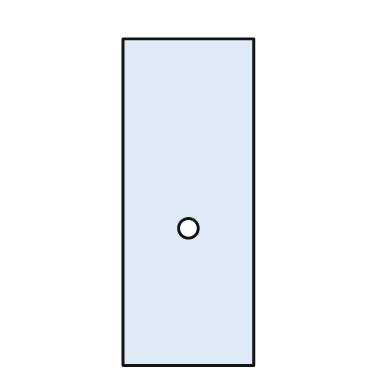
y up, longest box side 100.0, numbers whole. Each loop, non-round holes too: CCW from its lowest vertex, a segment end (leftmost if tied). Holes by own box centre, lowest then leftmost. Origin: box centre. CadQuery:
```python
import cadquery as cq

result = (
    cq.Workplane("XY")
    .moveTo(-20.0, -50.0)
    .lineTo(20.0, -50.0)
    .lineTo(20.0, 50.0)
    .lineTo(-20.0, 50.0)
    .close()
    .moveTo(0.0, -8.0)
    .circle(3.0)
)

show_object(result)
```